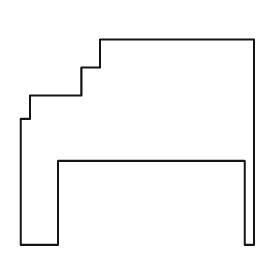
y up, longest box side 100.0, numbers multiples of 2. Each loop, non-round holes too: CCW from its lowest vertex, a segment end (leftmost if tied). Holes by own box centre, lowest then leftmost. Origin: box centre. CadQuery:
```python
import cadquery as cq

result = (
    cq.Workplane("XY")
    .moveTo(-50.0, -44.0)
    .lineTo(-34.0, -44.0)
    .lineTo(-34.0, -8.0)
    .lineTo(46.0, -8.0)
    .lineTo(46.0, -44.0)
    .lineTo(50.0, -44.0)
    .lineTo(50.0, 44.0)
    .lineTo(-16.0, 44.0)
    .lineTo(-16.0, 32.0)
    .lineTo(-24.0, 32.0)
    .lineTo(-24.0, 20.0)
    .lineTo(-46.0, 20.0)
    .lineTo(-46.0, 10.0)
    .lineTo(-50.0, 10.0)
    .close()
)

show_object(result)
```